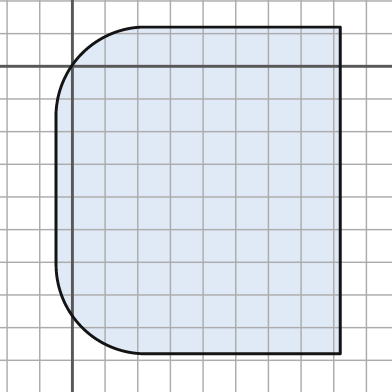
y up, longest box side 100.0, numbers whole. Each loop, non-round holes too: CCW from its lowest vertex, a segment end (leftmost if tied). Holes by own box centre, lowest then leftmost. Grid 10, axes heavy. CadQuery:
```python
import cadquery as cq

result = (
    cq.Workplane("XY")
    .moveTo(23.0, -88.0)
    .lineTo(82.0, -88.0)
    .lineTo(82.0, 12.0)
    .lineTo(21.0, 12.0)
    .threePointArc((3.0, 4.0), (-5.0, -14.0))
    .lineTo(-5.0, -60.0)
    .threePointArc((3.0, -80.0), (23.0, -88.0))
    .close()
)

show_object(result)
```